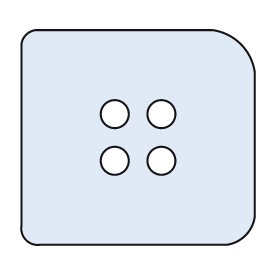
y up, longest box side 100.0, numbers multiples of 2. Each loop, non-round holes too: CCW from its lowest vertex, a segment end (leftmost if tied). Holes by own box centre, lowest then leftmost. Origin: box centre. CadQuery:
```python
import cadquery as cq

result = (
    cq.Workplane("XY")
    .moveTo(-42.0, -46.0)
    .lineTo(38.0, -46.0)
    .threePointArc((46.0, -42.0), (50.0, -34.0))
    .lineTo(50.0, 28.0)
    .threePointArc((44.0, 40.0), (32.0, 46.0))
    .lineTo(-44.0, 46.0)
    .threePointArc((-48.0, 44.0), (-50.0, 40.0))
    .lineTo(-50.0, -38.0)
    .threePointArc((-48.0, -44.0), (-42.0, -46.0))
    .close()
    .moveTo(-10.0, -10.0)
    .circle(6.0)
    .moveTo(10.0, -10.0)
    .circle(6.0)
    .moveTo(-10.0, 10.0)
    .circle(6.0)
    .moveTo(10.0, 10.0)
    .circle(6.0)
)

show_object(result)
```